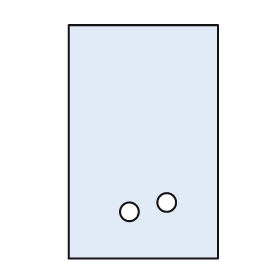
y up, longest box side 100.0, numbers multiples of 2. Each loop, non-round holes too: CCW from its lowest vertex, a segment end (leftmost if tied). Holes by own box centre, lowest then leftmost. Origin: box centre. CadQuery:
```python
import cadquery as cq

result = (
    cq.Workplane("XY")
    .moveTo(-32.0, -50.0)
    .lineTo(32.0, -50.0)
    .lineTo(32.0, 50.0)
    .lineTo(-32.0, 50.0)
    .close()
    .moveTo(-6.0, -30.0)
    .circle(4.0)
    .moveTo(10.0, -26.0)
    .circle(4.0)
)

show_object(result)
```